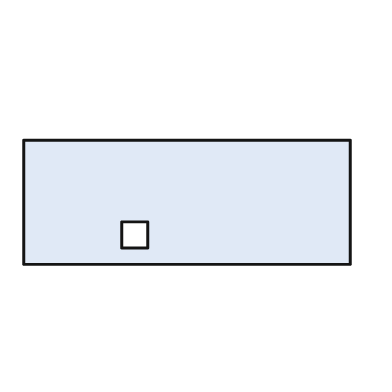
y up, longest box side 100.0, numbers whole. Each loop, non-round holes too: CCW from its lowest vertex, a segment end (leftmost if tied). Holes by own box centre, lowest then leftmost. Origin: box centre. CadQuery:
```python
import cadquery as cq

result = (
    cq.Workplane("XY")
    .moveTo(-50.0, -19.0)
    .lineTo(50.0, -19.0)
    .lineTo(50.0, 19.0)
    .lineTo(-50.0, 19.0)
    .close()
    .moveTo(-20.0, -14.0)
    .lineTo(-12.0, -14.0)
    .lineTo(-12.0, -6.0)
    .lineTo(-20.0, -6.0)
    .close()
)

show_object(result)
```